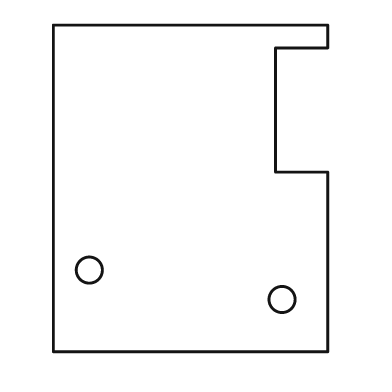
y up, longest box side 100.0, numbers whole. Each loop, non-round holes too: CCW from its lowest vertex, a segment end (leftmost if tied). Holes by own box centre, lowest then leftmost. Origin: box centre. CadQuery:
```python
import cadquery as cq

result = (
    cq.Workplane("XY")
    .moveTo(-42.0, -50.0)
    .lineTo(42.0, -50.0)
    .lineTo(42.0, 5.0)
    .lineTo(26.0, 5.0)
    .lineTo(26.0, 43.0)
    .lineTo(42.0, 43.0)
    .lineTo(42.0, 50.0)
    .lineTo(-42.0, 50.0)
    .close()
    .moveTo(28.0, -34.0)
    .circle(4.0)
    .moveTo(-31.0, -25.0)
    .circle(4.0)
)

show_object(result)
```